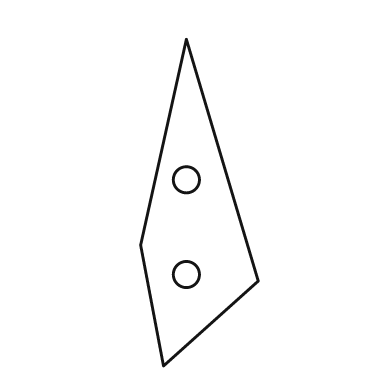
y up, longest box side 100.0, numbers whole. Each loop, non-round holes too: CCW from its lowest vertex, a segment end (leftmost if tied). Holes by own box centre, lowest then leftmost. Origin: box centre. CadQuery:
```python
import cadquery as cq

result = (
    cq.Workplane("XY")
    .moveTo(-11.0, -50.0)
    .lineTo(18.0, -24.0)
    .lineTo(-4.0, 50.0)
    .lineTo(-18.0, -13.0)
    .close()
    .moveTo(-4.0, -22.0)
    .circle(4.0)
    .moveTo(-4.0, 7.0)
    .circle(4.0)
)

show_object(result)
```